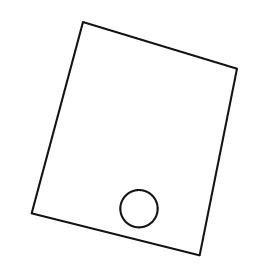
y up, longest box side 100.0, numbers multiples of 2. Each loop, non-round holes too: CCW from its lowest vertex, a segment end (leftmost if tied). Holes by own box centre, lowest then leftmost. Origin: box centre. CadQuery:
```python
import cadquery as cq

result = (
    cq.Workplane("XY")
    .moveTo(28.0, -50.0)
    .lineTo(44.0, 30.0)
    .lineTo(-22.0, 50.0)
    .lineTo(-44.0, -32.0)
    .close()
    .moveTo(2.0, -30.0)
    .circle(8.0)
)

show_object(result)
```